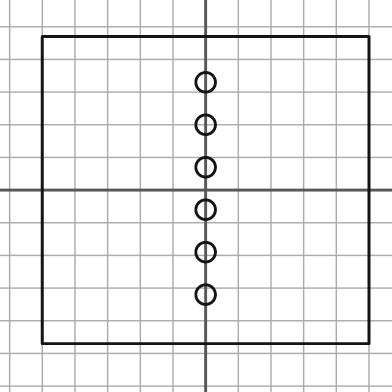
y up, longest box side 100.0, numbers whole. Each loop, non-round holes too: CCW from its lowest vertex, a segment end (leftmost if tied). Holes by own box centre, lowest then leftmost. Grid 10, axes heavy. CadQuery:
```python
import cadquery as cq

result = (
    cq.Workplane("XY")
    .moveTo(-50.0, -47.0)
    .lineTo(50.0, -47.0)
    .lineTo(50.0, 47.0)
    .lineTo(-50.0, 47.0)
    .close()
    .moveTo(0.0, -32.0)
    .circle(3.0)
    .moveTo(0.0, -19.0)
    .circle(3.0)
    .moveTo(0.0, -6.0)
    .circle(3.0)
    .moveTo(0.0, 7.0)
    .circle(3.0)
    .moveTo(0.0, 20.0)
    .circle(3.0)
    .moveTo(0.0, 33.0)
    .circle(3.0)
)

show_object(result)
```